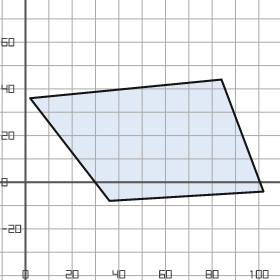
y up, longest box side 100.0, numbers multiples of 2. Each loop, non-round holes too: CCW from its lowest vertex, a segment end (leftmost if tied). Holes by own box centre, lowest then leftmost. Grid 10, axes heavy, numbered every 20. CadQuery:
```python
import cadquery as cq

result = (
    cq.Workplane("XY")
    .moveTo(36.0, -8.0)
    .lineTo(102.0, -4.0)
    .lineTo(84.0, 44.0)
    .lineTo(2.0, 36.0)
    .close()
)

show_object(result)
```